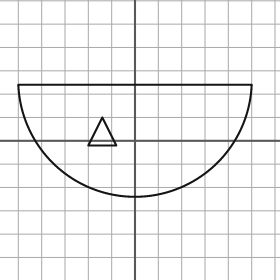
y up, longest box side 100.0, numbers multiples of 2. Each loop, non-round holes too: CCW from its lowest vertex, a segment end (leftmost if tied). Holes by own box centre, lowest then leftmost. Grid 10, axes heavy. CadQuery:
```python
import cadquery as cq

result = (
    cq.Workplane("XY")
    .moveTo(-50.0, 24.0)
    .threePointArc((0.0, -24.0), (50.0, 24.0))
    .close()
    .moveTo(-20.0, -2.0)
    .lineTo(-8.0, -2.0)
    .lineTo(-14.0, 10.0)
    .close()
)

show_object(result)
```